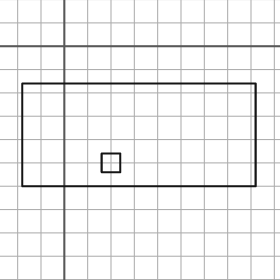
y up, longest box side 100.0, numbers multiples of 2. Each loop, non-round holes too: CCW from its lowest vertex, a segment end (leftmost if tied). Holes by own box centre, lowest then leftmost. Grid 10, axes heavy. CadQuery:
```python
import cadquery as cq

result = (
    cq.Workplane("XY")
    .moveTo(-18.0, -60.0)
    .lineTo(82.0, -60.0)
    .lineTo(82.0, -16.0)
    .lineTo(-18.0, -16.0)
    .close()
    .moveTo(16.0, -54.0)
    .lineTo(24.0, -54.0)
    .lineTo(24.0, -46.0)
    .lineTo(16.0, -46.0)
    .close()
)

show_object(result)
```